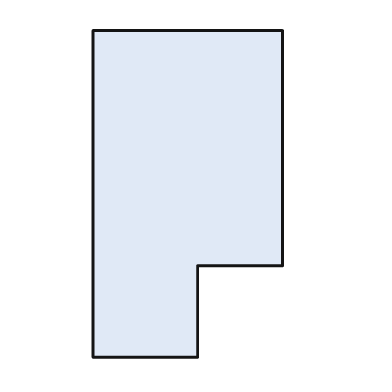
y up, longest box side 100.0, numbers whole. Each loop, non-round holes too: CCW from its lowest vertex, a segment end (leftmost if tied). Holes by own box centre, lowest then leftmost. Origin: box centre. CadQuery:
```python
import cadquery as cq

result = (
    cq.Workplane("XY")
    .moveTo(-29.0, -50.0)
    .lineTo(3.0, -50.0)
    .lineTo(3.0, -22.0)
    .lineTo(29.0, -22.0)
    .lineTo(29.0, 50.0)
    .lineTo(-29.0, 50.0)
    .close()
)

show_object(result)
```